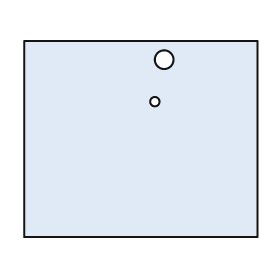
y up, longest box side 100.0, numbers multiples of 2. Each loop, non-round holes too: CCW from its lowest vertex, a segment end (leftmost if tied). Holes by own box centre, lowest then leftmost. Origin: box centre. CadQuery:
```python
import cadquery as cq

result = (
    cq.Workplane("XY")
    .moveTo(-50.0, -42.0)
    .lineTo(50.0, -42.0)
    .lineTo(50.0, 42.0)
    .lineTo(-50.0, 42.0)
    .close()
    .moveTo(6.0, 16.0)
    .circle(2.0)
    .moveTo(10.0, 34.0)
    .circle(4.0)
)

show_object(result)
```